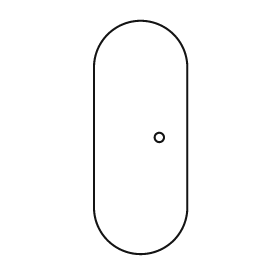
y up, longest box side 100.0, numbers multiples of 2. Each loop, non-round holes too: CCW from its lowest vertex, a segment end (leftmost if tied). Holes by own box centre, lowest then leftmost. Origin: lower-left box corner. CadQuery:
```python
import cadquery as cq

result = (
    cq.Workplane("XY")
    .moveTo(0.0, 20.0)
    .threePointArc((20.0, 0.0), (40.0, 20.0))
    .lineTo(40.0, 80.0)
    .threePointArc((20.0, 100.0), (0.0, 80.0))
    .close()
    .moveTo(28.0, 50.0)
    .circle(2.0)
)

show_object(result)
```